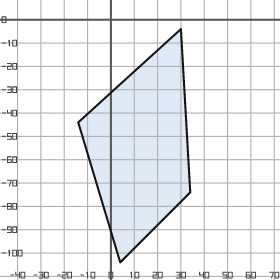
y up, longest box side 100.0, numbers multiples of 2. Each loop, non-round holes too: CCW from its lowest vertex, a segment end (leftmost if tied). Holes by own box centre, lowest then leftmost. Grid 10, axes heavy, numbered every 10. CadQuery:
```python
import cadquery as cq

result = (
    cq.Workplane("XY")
    .moveTo(4.0, -104.0)
    .lineTo(34.0, -74.0)
    .lineTo(30.0, -4.0)
    .lineTo(-14.0, -44.0)
    .close()
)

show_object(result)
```